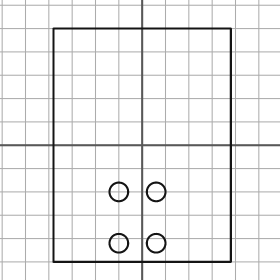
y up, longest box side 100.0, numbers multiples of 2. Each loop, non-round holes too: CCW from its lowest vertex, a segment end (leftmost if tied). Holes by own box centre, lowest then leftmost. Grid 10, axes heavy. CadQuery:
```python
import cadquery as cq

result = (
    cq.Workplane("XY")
    .moveTo(-38.0, -50.0)
    .lineTo(38.0, -50.0)
    .lineTo(38.0, 50.0)
    .lineTo(-38.0, 50.0)
    .close()
    .moveTo(-10.0, -42.0)
    .circle(4.0)
    .moveTo(6.0, -42.0)
    .circle(4.0)
    .moveTo(-10.0, -20.0)
    .circle(4.0)
    .moveTo(6.0, -20.0)
    .circle(4.0)
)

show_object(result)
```